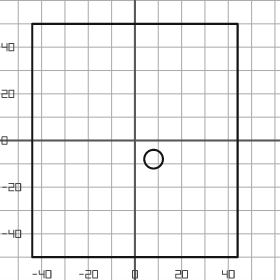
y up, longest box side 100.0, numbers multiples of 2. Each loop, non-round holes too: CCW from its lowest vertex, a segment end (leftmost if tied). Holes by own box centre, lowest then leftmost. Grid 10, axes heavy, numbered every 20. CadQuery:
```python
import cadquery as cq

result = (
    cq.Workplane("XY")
    .moveTo(-44.0, -50.0)
    .lineTo(44.0, -50.0)
    .lineTo(44.0, 50.0)
    .lineTo(-44.0, 50.0)
    .close()
    .moveTo(8.0, -8.0)
    .circle(4.0)
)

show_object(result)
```